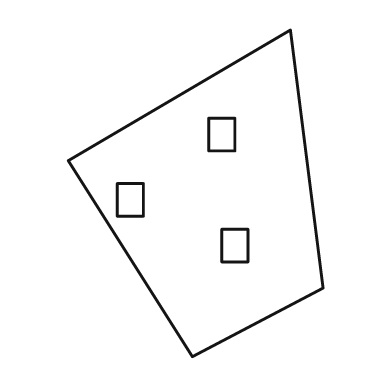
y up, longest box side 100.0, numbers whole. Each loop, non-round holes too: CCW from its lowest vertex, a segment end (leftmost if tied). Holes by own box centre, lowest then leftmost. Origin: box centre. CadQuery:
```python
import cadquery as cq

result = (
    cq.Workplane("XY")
    .moveTo(-1.0, -50.0)
    .lineTo(39.0, -29.0)
    .lineTo(29.0, 50.0)
    .lineTo(-39.0, 10.0)
    .close()
    .moveTo(8.0, -21.0)
    .lineTo(16.0, -21.0)
    .lineTo(16.0, -11.0)
    .lineTo(8.0, -11.0)
    .close()
    .moveTo(-24.0, -7.0)
    .lineTo(-16.0, -7.0)
    .lineTo(-16.0, 3.0)
    .lineTo(-24.0, 3.0)
    .close()
    .moveTo(4.0, 13.0)
    .lineTo(12.0, 13.0)
    .lineTo(12.0, 23.0)
    .lineTo(4.0, 23.0)
    .close()
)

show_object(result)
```